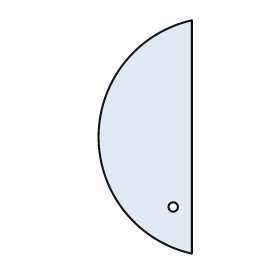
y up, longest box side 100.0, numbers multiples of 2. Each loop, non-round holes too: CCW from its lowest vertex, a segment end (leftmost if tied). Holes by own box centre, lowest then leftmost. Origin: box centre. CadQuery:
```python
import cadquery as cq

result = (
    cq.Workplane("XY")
    .moveTo(20.0, -50.0)
    .lineTo(20.0, 50.0)
    .threePointArc((-20.0, 0.0), (20.0, -50.0))
    .close()
    .moveTo(12.0, -30.0)
    .circle(2.0)
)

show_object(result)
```